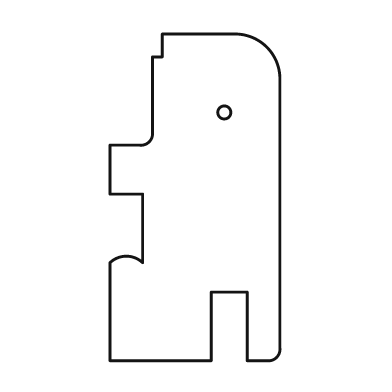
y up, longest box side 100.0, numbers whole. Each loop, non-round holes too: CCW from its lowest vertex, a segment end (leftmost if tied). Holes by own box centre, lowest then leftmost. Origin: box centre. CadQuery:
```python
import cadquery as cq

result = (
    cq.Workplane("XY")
    .moveTo(-26.0, -50.0)
    .lineTo(5.0, -50.0)
    .lineTo(5.0, -29.0)
    .lineTo(16.0, -29.0)
    .lineTo(16.0, -50.0)
    .lineTo(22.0, -50.0)
    .threePointArc((25.0, -49.0), (26.0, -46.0))
    .lineTo(26.0, 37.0)
    .threePointArc((22.0, 46.0), (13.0, 50.0))
    .lineTo(-10.0, 50.0)
    .lineTo(-10.0, 43.0)
    .lineTo(-13.0, 43.0)
    .lineTo(-13.0, 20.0)
    .threePointArc((-14.0, 17.0), (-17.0, 16.0))
    .lineTo(-26.0, 16.0)
    .lineTo(-26.0, 1.0)
    .lineTo(-16.0, 1.0)
    .lineTo(-16.0, -20.0)
    .threePointArc((-21.0, -18.0), (-26.0, -20.0))
    .close()
    .moveTo(9.0, 26.0)
    .circle(2.0)
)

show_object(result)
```